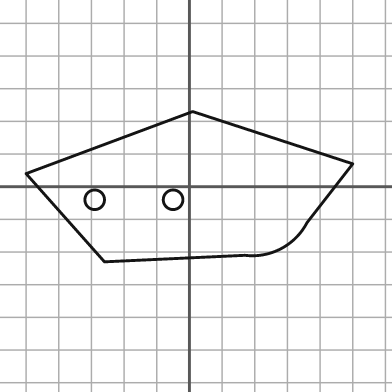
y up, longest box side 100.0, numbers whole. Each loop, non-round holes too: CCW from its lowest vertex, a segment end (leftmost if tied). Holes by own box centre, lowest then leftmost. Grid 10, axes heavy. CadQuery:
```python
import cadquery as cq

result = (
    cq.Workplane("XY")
    .moveTo(-26.0, -23.0)
    .lineTo(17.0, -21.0)
    .threePointArc((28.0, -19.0), (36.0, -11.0))
    .lineTo(50.0, 7.0)
    .lineTo(1.0, 23.0)
    .lineTo(-50.0, 4.0)
    .close()
    .moveTo(-29.0, -4.0)
    .circle(3.0)
    .moveTo(-5.0, -4.0)
    .circle(3.0)
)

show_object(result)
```